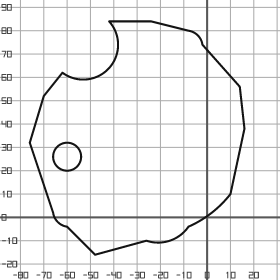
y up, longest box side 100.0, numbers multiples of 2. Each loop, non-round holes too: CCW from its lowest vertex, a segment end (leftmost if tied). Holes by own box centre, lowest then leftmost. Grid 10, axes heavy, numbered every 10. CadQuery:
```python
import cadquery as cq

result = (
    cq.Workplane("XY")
    .moveTo(-48.0, -16.0)
    .lineTo(-26.0, -10.0)
    .threePointArc((-16.0, -10.0), (-8.0, -4.0))
    .threePointArc((2.0, 2.0), (10.0, 10.0))
    .lineTo(16.0, 38.0)
    .lineTo(14.0, 56.0)
    .lineTo(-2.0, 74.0)
    .threePointArc((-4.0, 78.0), (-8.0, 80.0))
    .lineTo(-24.0, 84.0)
    .lineTo(-42.0, 84.0)
    .threePointArc((-42.0, 64.0), (-62.0, 62.0))
    .lineTo(-70.0, 52.0)
    .lineTo(-76.0, 32.0)
    .lineTo(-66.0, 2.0)
    .threePointArc((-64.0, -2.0), (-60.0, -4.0))
    .close()
    .moveTo(-60.0, 26.0)
    .circle(6.0)
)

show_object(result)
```